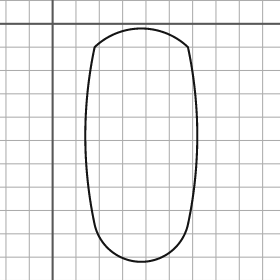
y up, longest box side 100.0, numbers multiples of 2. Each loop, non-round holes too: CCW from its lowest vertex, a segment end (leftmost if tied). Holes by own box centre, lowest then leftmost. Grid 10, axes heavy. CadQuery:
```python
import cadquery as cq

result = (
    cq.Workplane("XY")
    .moveTo(18.0, -86.0)
    .threePointArc((38.0, -102.0), (58.0, -86.0))
    .threePointArc((62.0, -48.0), (58.0, -10.0))
    .threePointArc((38.0, -2.0), (18.0, -10.0))
    .threePointArc((14.0, -48.0), (18.0, -86.0))
    .close()
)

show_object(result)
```